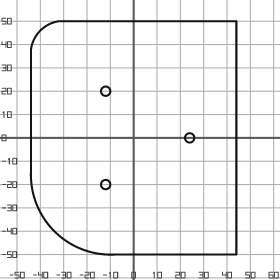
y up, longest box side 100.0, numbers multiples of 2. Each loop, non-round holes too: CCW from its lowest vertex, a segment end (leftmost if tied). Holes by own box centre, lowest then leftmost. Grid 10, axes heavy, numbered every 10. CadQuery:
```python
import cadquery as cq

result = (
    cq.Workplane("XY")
    .moveTo(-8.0, -50.0)
    .lineTo(44.0, -50.0)
    .lineTo(44.0, 50.0)
    .lineTo(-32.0, 50.0)
    .threePointArc((-40.0, 46.0), (-44.0, 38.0))
    .lineTo(-44.0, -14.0)
    .threePointArc((-34.0, -40.0), (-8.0, -50.0))
    .close()
    .moveTo(-12.0, -20.0)
    .circle(2.0)
    .moveTo(24.0, 0.0)
    .circle(2.0)
    .moveTo(-12.0, 20.0)
    .circle(2.0)
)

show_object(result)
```